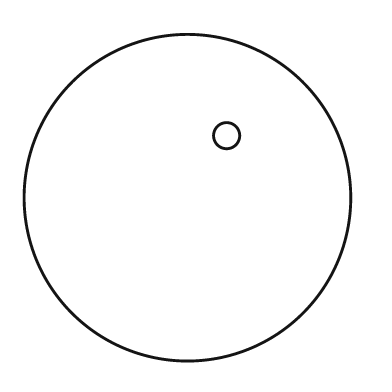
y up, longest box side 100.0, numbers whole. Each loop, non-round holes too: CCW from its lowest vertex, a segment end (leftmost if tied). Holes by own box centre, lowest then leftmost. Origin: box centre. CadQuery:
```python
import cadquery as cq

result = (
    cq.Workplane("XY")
    .moveTo(0.0, 0.0)
    .circle(50.0)
    .moveTo(12.0, 19.0)
    .circle(4.0)
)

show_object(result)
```